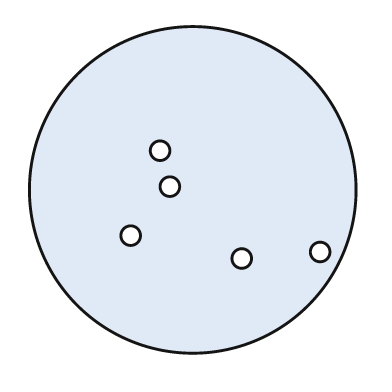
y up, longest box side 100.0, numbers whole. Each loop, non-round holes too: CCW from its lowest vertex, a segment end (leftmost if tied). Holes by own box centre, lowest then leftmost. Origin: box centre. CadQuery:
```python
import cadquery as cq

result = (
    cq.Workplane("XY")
    .moveTo(0.0, 0.0)
    .circle(50.0)
    .moveTo(15.0, -21.0)
    .circle(3.0)
    .moveTo(39.0, -19.0)
    .circle(3.0)
    .moveTo(-19.0, -14.0)
    .circle(3.0)
    .moveTo(-7.0, 1.0)
    .circle(3.0)
    .moveTo(-10.0, 12.0)
    .circle(3.0)
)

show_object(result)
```